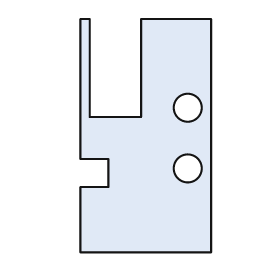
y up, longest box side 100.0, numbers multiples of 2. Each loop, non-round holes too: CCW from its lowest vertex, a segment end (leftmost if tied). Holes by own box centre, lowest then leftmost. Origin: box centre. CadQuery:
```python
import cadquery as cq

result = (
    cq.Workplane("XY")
    .moveTo(-28.0, -50.0)
    .lineTo(28.0, -50.0)
    .lineTo(28.0, 50.0)
    .lineTo(-2.0, 50.0)
    .lineTo(-2.0, 8.0)
    .lineTo(-24.0, 8.0)
    .lineTo(-24.0, 50.0)
    .lineTo(-28.0, 50.0)
    .lineTo(-28.0, -10.0)
    .lineTo(-16.0, -10.0)
    .lineTo(-16.0, -22.0)
    .lineTo(-28.0, -22.0)
    .close()
    .moveTo(18.0, -14.0)
    .circle(6.0)
    .moveTo(18.0, 12.0)
    .circle(6.0)
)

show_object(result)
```